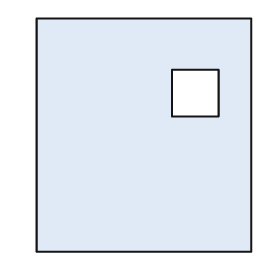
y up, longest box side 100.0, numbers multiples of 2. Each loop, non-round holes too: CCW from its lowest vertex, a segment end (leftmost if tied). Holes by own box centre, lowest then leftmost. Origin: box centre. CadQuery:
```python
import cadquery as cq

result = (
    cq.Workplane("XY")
    .moveTo(-46.0, -50.0)
    .lineTo(46.0, -50.0)
    .lineTo(46.0, 50.0)
    .lineTo(-46.0, 50.0)
    .close()
    .moveTo(12.0, 8.0)
    .lineTo(32.0, 8.0)
    .lineTo(32.0, 28.0)
    .lineTo(12.0, 28.0)
    .close()
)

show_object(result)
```